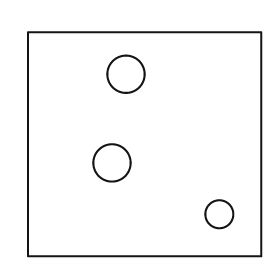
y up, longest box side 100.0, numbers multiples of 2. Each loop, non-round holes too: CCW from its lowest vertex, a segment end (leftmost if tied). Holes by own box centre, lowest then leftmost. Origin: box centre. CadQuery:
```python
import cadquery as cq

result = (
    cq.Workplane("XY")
    .moveTo(-50.0, -48.0)
    .lineTo(50.0, -48.0)
    .lineTo(50.0, 48.0)
    .lineTo(-50.0, 48.0)
    .close()
    .moveTo(32.0, -30.0)
    .circle(6.0)
    .moveTo(-14.0, -8.0)
    .circle(8.0)
    .moveTo(-8.0, 30.0)
    .circle(8.0)
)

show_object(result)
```